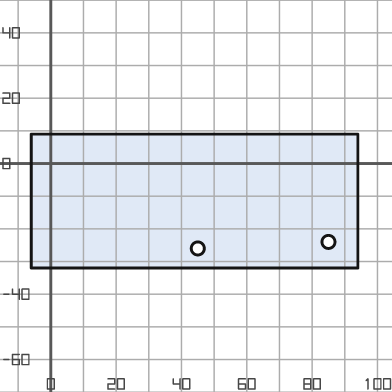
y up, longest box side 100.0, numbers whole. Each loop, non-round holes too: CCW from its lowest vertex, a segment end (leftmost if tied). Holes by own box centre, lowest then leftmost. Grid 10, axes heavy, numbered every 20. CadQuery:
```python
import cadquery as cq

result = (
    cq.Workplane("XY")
    .moveTo(-6.0, -32.0)
    .lineTo(94.0, -32.0)
    .lineTo(94.0, 9.0)
    .lineTo(-6.0, 9.0)
    .close()
    .moveTo(45.0, -26.0)
    .circle(2.0)
    .moveTo(85.0, -24.0)
    .circle(2.0)
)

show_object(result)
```